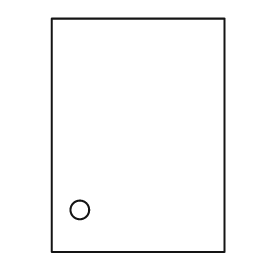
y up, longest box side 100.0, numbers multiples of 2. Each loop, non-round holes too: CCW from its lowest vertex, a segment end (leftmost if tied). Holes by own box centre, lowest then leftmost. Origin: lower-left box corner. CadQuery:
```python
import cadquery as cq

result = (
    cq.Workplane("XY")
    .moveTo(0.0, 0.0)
    .lineTo(74.0, 0.0)
    .lineTo(74.0, 100.0)
    .lineTo(0.0, 100.0)
    .close()
    .moveTo(12.0, 18.0)
    .circle(4.0)
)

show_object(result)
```